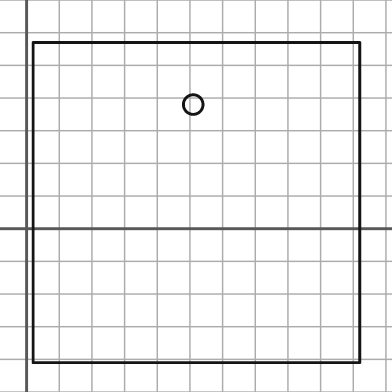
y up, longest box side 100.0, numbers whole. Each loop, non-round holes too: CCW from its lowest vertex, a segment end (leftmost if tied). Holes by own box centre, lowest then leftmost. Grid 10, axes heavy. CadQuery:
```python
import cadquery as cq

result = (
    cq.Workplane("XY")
    .moveTo(2.0, -41.0)
    .lineTo(102.0, -41.0)
    .lineTo(102.0, 57.0)
    .lineTo(2.0, 57.0)
    .close()
    .moveTo(51.0, 38.0)
    .circle(3.0)
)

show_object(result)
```